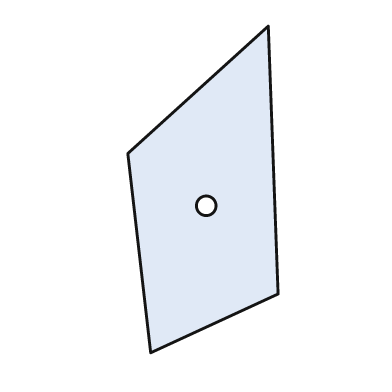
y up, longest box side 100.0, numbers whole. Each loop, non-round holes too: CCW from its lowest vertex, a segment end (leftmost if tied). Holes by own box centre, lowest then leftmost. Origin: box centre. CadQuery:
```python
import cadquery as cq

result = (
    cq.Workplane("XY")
    .moveTo(-16.0, -50.0)
    .lineTo(23.0, -32.0)
    .lineTo(20.0, 50.0)
    .lineTo(-23.0, 11.0)
    .close()
    .moveTo(1.0, -5.0)
    .circle(3.0)
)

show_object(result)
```